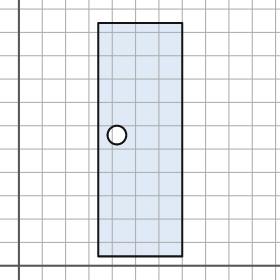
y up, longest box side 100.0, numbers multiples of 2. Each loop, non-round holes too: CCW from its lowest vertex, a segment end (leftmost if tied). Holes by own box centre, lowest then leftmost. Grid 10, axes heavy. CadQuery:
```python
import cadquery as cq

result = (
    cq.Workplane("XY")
    .moveTo(34.0, 4.0)
    .lineTo(70.0, 4.0)
    .lineTo(70.0, 104.0)
    .lineTo(34.0, 104.0)
    .close()
    .moveTo(42.0, 56.0)
    .circle(4.0)
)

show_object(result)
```